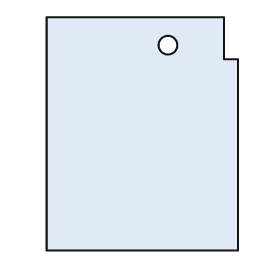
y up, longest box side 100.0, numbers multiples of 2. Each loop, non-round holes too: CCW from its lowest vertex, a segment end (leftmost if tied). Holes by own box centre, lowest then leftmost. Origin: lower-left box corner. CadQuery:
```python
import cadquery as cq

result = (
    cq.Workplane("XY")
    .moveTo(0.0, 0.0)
    .lineTo(82.0, 0.0)
    .lineTo(82.0, 82.0)
    .lineTo(76.0, 82.0)
    .lineTo(76.0, 100.0)
    .lineTo(0.0, 100.0)
    .close()
    .moveTo(52.0, 88.0)
    .circle(4.0)
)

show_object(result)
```